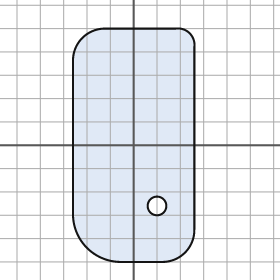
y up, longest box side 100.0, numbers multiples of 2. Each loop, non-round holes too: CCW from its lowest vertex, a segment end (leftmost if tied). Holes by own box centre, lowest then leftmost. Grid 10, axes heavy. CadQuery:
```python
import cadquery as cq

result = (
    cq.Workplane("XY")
    .moveTo(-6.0, -50.0)
    .lineTo(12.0, -50.0)
    .threePointArc((22.0, -46.0), (26.0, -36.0))
    .lineTo(26.0, 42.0)
    .threePointArc((24.0, 48.0), (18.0, 50.0))
    .lineTo(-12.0, 50.0)
    .threePointArc((-22.0, 46.0), (-26.0, 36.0))
    .lineTo(-26.0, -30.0)
    .threePointArc((-20.0, -44.0), (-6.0, -50.0))
    .close()
    .moveTo(10.0, -26.0)
    .circle(4.0)
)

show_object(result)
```